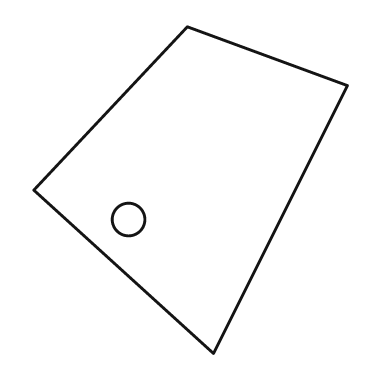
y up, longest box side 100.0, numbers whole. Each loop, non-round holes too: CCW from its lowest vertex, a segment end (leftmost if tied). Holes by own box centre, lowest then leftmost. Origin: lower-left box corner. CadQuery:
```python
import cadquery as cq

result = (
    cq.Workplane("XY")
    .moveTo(55.0, 0.0)
    .lineTo(96.0, 82.0)
    .lineTo(47.0, 100.0)
    .lineTo(0.0, 50.0)
    .close()
    .moveTo(29.0, 41.0)
    .circle(5.0)
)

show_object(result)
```